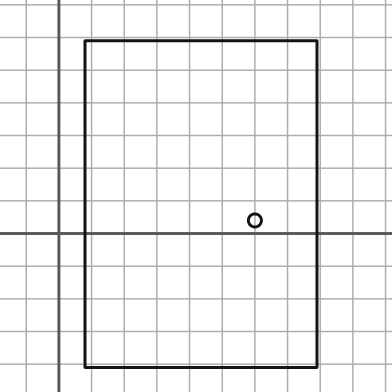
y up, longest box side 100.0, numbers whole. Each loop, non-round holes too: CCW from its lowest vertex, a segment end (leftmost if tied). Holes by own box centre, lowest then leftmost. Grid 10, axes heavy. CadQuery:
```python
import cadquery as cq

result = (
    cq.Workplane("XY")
    .moveTo(8.0, -41.0)
    .lineTo(79.0, -41.0)
    .lineTo(79.0, 59.0)
    .lineTo(8.0, 59.0)
    .close()
    .moveTo(60.0, 4.0)
    .circle(2.0)
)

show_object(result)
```